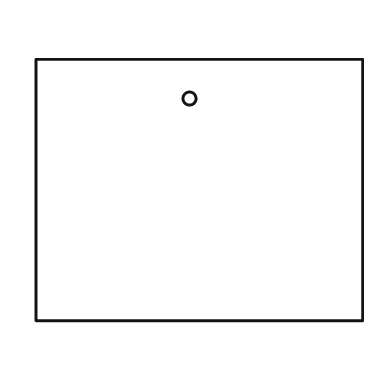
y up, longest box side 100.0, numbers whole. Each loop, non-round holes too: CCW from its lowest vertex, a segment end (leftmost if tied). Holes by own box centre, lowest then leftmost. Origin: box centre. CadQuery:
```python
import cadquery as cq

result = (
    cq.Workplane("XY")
    .moveTo(-50.0, -40.0)
    .lineTo(50.0, -40.0)
    .lineTo(50.0, 40.0)
    .lineTo(-50.0, 40.0)
    .close()
    .moveTo(-3.0, 28.0)
    .circle(2.0)
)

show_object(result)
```